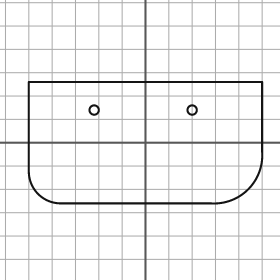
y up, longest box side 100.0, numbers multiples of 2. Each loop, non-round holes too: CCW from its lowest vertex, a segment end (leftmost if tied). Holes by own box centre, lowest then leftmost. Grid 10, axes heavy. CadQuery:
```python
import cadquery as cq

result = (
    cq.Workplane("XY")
    .moveTo(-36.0, -26.0)
    .lineTo(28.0, -26.0)
    .threePointArc((44.0, -20.0), (50.0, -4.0))
    .lineTo(50.0, 26.0)
    .lineTo(-50.0, 26.0)
    .lineTo(-50.0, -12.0)
    .threePointArc((-46.0, -22.0), (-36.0, -26.0))
    .close()
    .moveTo(-22.0, 14.0)
    .circle(2.0)
    .moveTo(20.0, 14.0)
    .circle(2.0)
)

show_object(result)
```